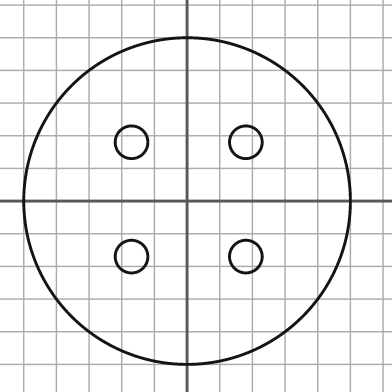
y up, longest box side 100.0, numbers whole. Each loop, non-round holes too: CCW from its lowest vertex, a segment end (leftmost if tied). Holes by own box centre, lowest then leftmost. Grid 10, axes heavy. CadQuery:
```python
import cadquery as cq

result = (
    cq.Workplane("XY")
    .moveTo(0.0, 0.0)
    .circle(50.0)
    .moveTo(-17.0, -17.0)
    .circle(5.0)
    .moveTo(18.0, -17.0)
    .circle(5.0)
    .moveTo(-17.0, 18.0)
    .circle(5.0)
    .moveTo(18.0, 18.0)
    .circle(5.0)
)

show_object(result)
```